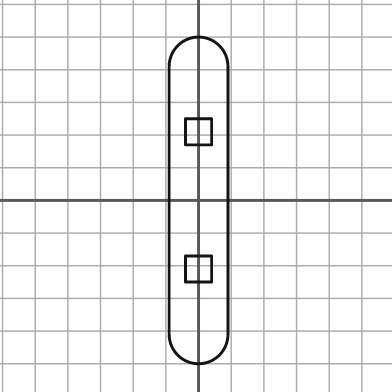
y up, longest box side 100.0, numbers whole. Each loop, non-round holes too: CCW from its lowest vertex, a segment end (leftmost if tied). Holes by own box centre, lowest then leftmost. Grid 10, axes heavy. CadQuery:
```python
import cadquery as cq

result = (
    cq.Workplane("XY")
    .moveTo(-9.0, -41.0)
    .threePointArc((0.0, -50.0), (9.0, -41.0))
    .lineTo(9.0, 41.0)
    .threePointArc((0.0, 50.0), (-9.0, 41.0))
    .close()
    .moveTo(-4.0, -25.0)
    .lineTo(4.0, -25.0)
    .lineTo(4.0, -17.0)
    .lineTo(-4.0, -17.0)
    .close()
    .moveTo(-4.0, 17.0)
    .lineTo(4.0, 17.0)
    .lineTo(4.0, 25.0)
    .lineTo(-4.0, 25.0)
    .close()
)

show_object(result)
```